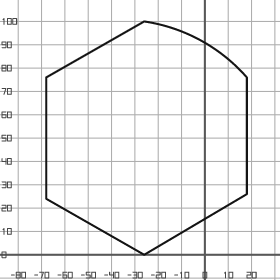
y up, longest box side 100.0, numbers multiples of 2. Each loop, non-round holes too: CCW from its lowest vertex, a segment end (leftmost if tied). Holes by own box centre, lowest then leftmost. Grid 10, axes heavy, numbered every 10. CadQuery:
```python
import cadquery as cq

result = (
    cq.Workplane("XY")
    .moveTo(-26.0, 0.0)
    .lineTo(18.0, 26.0)
    .lineTo(18.0, 76.0)
    .threePointArc((-2.0, 92.0), (-26.0, 100.0))
    .lineTo(-68.0, 76.0)
    .lineTo(-68.0, 24.0)
    .close()
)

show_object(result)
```